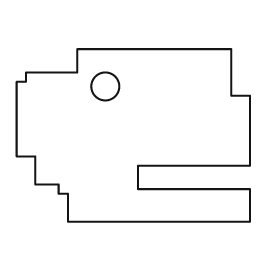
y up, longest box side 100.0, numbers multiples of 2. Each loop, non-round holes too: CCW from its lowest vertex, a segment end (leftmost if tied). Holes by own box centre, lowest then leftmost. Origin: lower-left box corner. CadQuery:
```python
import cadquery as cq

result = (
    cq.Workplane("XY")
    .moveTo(22.0, 0.0)
    .lineTo(100.0, 0.0)
    .lineTo(100.0, 14.0)
    .lineTo(52.0, 14.0)
    .lineTo(52.0, 24.0)
    .lineTo(100.0, 24.0)
    .lineTo(100.0, 54.0)
    .lineTo(92.0, 54.0)
    .lineTo(92.0, 74.0)
    .lineTo(26.0, 74.0)
    .lineTo(26.0, 64.0)
    .lineTo(4.0, 64.0)
    .lineTo(4.0, 60.0)
    .lineTo(0.0, 60.0)
    .lineTo(0.0, 28.0)
    .lineTo(8.0, 28.0)
    .lineTo(8.0, 16.0)
    .lineTo(18.0, 16.0)
    .lineTo(18.0, 12.0)
    .lineTo(22.0, 12.0)
    .close()
    .moveTo(38.0, 58.0)
    .circle(6.0)
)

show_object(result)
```